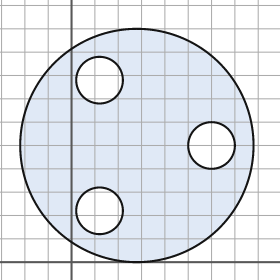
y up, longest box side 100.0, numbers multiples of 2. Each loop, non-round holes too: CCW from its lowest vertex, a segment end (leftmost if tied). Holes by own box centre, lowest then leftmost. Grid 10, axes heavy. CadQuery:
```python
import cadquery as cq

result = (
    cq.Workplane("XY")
    .moveTo(28.0, 50.0)
    .circle(50.0)
    .moveTo(12.0, 22.0)
    .circle(10.0)
    .moveTo(60.0, 50.0)
    .circle(10.0)
    .moveTo(12.0, 78.0)
    .circle(10.0)
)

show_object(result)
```